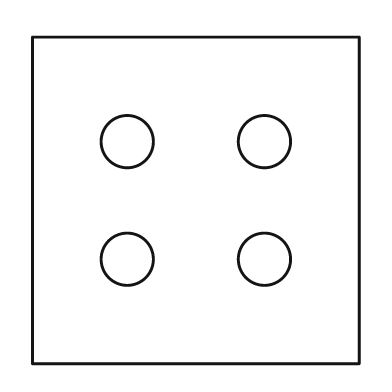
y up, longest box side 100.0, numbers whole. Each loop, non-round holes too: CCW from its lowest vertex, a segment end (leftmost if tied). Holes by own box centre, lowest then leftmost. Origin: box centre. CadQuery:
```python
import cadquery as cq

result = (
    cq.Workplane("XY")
    .moveTo(-50.0, -50.0)
    .lineTo(50.0, -50.0)
    .lineTo(50.0, 50.0)
    .lineTo(-50.0, 50.0)
    .close()
    .moveTo(-21.0, -18.0)
    .circle(8.0)
    .moveTo(21.0, -18.0)
    .circle(8.0)
    .moveTo(-21.0, 18.0)
    .circle(8.0)
    .moveTo(21.0, 18.0)
    .circle(8.0)
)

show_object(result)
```